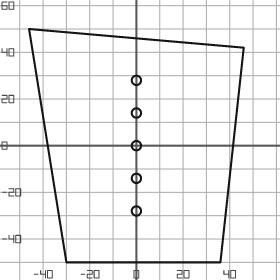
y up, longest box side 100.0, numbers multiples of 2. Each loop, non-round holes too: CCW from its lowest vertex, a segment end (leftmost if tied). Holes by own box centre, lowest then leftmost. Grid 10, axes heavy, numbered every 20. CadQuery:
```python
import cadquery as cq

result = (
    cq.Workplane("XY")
    .moveTo(-30.0, -50.0)
    .lineTo(36.0, -50.0)
    .lineTo(46.0, 42.0)
    .lineTo(-46.0, 50.0)
    .close()
    .moveTo(0.0, -28.0)
    .circle(2.0)
    .moveTo(0.0, -14.0)
    .circle(2.0)
    .moveTo(0.0, 0.0)
    .circle(2.0)
    .moveTo(0.0, 14.0)
    .circle(2.0)
    .moveTo(0.0, 28.0)
    .circle(2.0)
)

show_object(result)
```